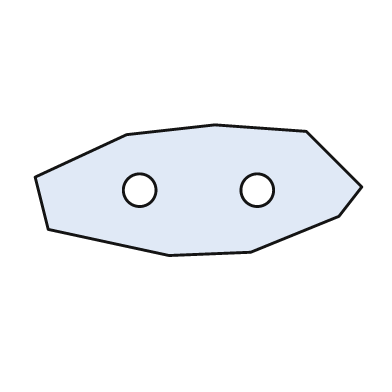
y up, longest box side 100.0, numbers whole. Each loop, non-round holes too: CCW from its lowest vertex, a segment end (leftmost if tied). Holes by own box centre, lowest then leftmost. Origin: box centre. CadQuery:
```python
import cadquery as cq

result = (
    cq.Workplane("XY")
    .moveTo(-9.0, -20.0)
    .lineTo(16.0, -19.0)
    .lineTo(43.0, -8.0)
    .lineTo(50.0, 1.0)
    .lineTo(33.0, 18.0)
    .lineTo(5.0, 20.0)
    .lineTo(-22.0, 17.0)
    .lineTo(-50.0, 4.0)
    .lineTo(-46.0, -12.0)
    .close()
    .moveTo(-18.0, 0.0)
    .circle(5.0)
    .moveTo(18.0, 0.0)
    .circle(5.0)
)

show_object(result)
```